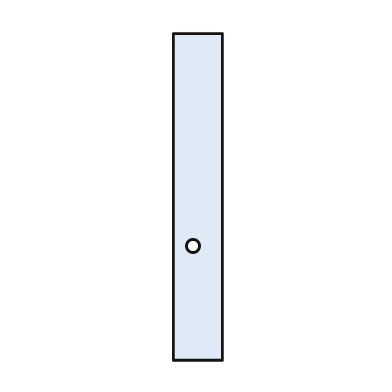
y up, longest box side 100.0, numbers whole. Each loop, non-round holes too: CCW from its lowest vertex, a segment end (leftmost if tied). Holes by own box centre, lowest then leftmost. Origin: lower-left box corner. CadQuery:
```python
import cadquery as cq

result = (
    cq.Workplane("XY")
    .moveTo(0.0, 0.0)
    .lineTo(15.0, 0.0)
    .lineTo(15.0, 100.0)
    .lineTo(0.0, 100.0)
    .close()
    .moveTo(6.0, 35.0)
    .circle(2.0)
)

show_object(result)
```